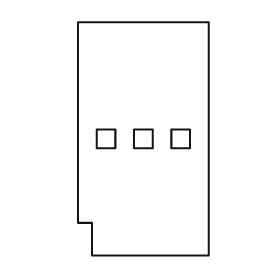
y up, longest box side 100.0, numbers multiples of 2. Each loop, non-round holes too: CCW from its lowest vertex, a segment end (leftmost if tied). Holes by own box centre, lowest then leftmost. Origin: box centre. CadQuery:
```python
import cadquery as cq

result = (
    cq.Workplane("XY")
    .moveTo(-22.0, -50.0)
    .lineTo(28.0, -50.0)
    .lineTo(28.0, 50.0)
    .lineTo(-28.0, 50.0)
    .lineTo(-28.0, -36.0)
    .lineTo(-22.0, -36.0)
    .close()
    .moveTo(-20.0, -4.0)
    .lineTo(-12.0, -4.0)
    .lineTo(-12.0, 4.0)
    .lineTo(-20.0, 4.0)
    .close()
    .moveTo(-4.0, -4.0)
    .lineTo(4.0, -4.0)
    .lineTo(4.0, 4.0)
    .lineTo(-4.0, 4.0)
    .close()
    .moveTo(12.0, -4.0)
    .lineTo(20.0, -4.0)
    .lineTo(20.0, 4.0)
    .lineTo(12.0, 4.0)
    .close()
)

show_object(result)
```